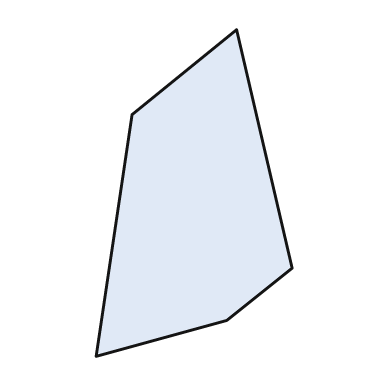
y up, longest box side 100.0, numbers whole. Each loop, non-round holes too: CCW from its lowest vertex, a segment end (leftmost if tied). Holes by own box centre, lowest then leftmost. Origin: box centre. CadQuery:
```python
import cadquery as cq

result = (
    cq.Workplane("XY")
    .moveTo(-30.0, -50.0)
    .lineTo(10.0, -39.0)
    .lineTo(30.0, -23.0)
    .lineTo(13.0, 50.0)
    .lineTo(-19.0, 24.0)
    .close()
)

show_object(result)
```